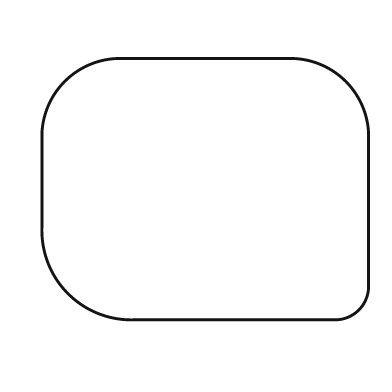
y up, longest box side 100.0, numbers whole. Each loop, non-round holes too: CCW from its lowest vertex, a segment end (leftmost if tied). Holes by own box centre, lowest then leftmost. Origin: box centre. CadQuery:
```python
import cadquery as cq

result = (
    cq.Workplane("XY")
    .moveTo(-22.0, -40.0)
    .lineTo(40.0, -40.0)
    .threePointArc((47.0, -37.0), (50.0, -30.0))
    .lineTo(50.0, 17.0)
    .threePointArc((43.0, 33.0), (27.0, 40.0))
    .lineTo(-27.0, 40.0)
    .threePointArc((-43.0, 33.0), (-50.0, 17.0))
    .lineTo(-50.0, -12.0)
    .threePointArc((-42.0, -32.0), (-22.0, -40.0))
    .close()
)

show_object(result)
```